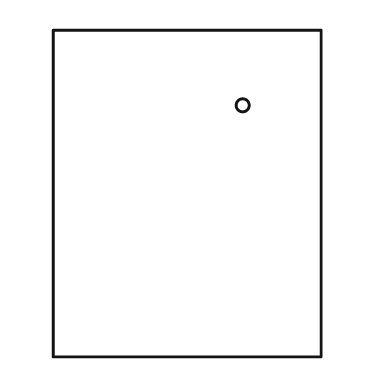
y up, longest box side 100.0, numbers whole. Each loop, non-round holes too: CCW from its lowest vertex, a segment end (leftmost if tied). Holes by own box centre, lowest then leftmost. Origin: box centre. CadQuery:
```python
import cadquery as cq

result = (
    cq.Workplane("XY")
    .moveTo(-41.0, -50.0)
    .lineTo(41.0, -50.0)
    .lineTo(41.0, 50.0)
    .lineTo(-41.0, 50.0)
    .close()
    .moveTo(17.0, 27.0)
    .circle(2.0)
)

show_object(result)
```